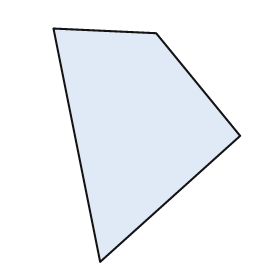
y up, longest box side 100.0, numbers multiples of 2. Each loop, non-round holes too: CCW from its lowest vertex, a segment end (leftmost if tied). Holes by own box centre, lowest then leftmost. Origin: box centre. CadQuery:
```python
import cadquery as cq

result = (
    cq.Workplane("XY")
    .moveTo(-20.0, -50.0)
    .lineTo(40.0, 4.0)
    .lineTo(4.0, 48.0)
    .lineTo(-40.0, 50.0)
    .close()
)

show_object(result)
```